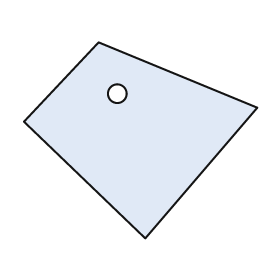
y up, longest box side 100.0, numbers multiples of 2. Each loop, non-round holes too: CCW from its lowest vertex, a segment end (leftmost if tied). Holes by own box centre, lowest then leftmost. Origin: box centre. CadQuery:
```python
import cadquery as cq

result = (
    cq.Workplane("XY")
    .moveTo(2.0, -42.0)
    .lineTo(50.0, 14.0)
    .lineTo(-18.0, 42.0)
    .lineTo(-50.0, 8.0)
    .close()
    .moveTo(-10.0, 20.0)
    .circle(4.0)
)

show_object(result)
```